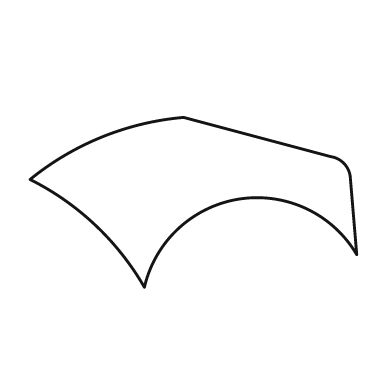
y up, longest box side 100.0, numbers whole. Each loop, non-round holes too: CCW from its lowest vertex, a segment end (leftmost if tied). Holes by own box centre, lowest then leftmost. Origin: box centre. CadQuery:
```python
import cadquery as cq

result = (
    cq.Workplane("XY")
    .moveTo(-15.0, -26.0)
    .threePointArc((14.0, 1.0), (50.0, -16.0))
    .lineTo(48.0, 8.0)
    .threePointArc((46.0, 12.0), (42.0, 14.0))
    .lineTo(-3.0, 26.0)
    .threePointArc((-28.0, 20.0), (-50.0, 7.0))
    .threePointArc((-30.0, -7.0), (-15.0, -26.0))
    .close()
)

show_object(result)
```